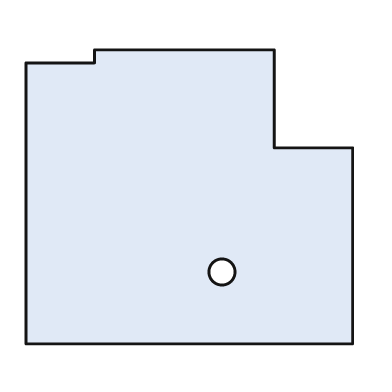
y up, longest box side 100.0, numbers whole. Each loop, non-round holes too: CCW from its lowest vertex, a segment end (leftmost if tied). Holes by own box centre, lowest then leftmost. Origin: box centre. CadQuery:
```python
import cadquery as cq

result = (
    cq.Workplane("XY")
    .moveTo(-50.0, -45.0)
    .lineTo(50.0, -45.0)
    .lineTo(50.0, 15.0)
    .lineTo(26.0, 15.0)
    .lineTo(26.0, 45.0)
    .lineTo(-29.0, 45.0)
    .lineTo(-29.0, 41.0)
    .lineTo(-50.0, 41.0)
    .close()
    .moveTo(10.0, -23.0)
    .circle(4.0)
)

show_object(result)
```